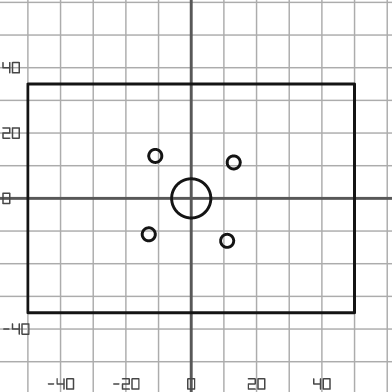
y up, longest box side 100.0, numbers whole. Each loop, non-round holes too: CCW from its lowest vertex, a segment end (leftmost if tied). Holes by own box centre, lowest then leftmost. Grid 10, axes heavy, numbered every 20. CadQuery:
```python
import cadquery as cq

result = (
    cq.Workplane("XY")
    .moveTo(-50.0, -35.0)
    .lineTo(50.0, -35.0)
    .lineTo(50.0, 35.0)
    .lineTo(-50.0, 35.0)
    .close()
    .moveTo(11.0, -13.0)
    .circle(2.0)
    .moveTo(-13.0, -11.0)
    .circle(2.0)
    .moveTo(0.0, 0.0)
    .circle(6.0)
    .moveTo(13.0, 11.0)
    .circle(2.0)
    .moveTo(-11.0, 13.0)
    .circle(2.0)
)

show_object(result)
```